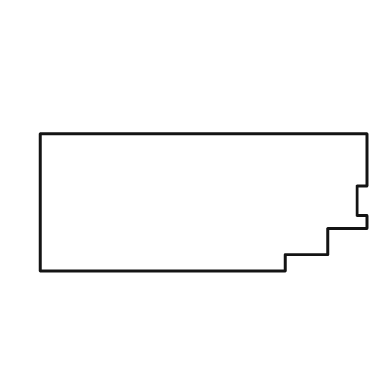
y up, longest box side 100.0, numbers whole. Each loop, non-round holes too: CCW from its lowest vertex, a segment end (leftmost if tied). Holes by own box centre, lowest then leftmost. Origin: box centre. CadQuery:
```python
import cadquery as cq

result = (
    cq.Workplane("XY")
    .moveTo(-50.0, -21.0)
    .lineTo(25.0, -21.0)
    .lineTo(25.0, -16.0)
    .lineTo(38.0, -16.0)
    .lineTo(38.0, -8.0)
    .lineTo(50.0, -8.0)
    .lineTo(50.0, -4.0)
    .lineTo(47.0, -4.0)
    .lineTo(47.0, 5.0)
    .lineTo(50.0, 5.0)
    .lineTo(50.0, 21.0)
    .lineTo(-50.0, 21.0)
    .close()
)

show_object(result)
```